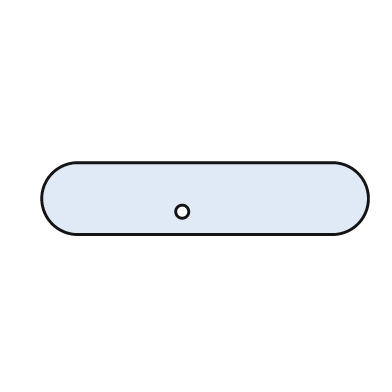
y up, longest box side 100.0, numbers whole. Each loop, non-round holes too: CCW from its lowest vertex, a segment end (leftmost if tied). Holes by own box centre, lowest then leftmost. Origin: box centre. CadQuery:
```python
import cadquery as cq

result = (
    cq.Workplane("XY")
    .moveTo(-39.0, -11.0)
    .lineTo(39.0, -11.0)
    .threePointArc((50.0, 0.0), (39.0, 11.0))
    .lineTo(-39.0, 11.0)
    .threePointArc((-50.0, 0.0), (-39.0, -11.0))
    .close()
    .moveTo(-7.0, -4.0)
    .circle(2.0)
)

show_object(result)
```